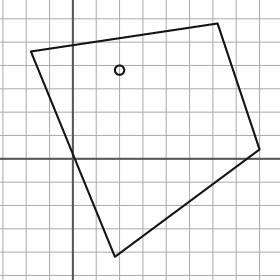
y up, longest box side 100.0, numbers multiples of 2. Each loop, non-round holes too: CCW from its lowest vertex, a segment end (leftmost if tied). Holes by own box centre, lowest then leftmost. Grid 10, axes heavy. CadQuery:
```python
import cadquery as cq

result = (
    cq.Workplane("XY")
    .moveTo(18.0, -42.0)
    .lineTo(80.0, 4.0)
    .lineTo(62.0, 58.0)
    .lineTo(-18.0, 46.0)
    .close()
    .moveTo(20.0, 38.0)
    .circle(2.0)
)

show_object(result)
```